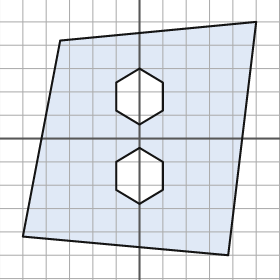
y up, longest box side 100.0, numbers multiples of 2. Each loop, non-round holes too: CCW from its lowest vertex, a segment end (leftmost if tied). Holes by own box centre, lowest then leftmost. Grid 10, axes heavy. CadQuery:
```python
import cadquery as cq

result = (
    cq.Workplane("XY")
    .moveTo(38.0, -50.0)
    .lineTo(50.0, 50.0)
    .lineTo(-34.0, 42.0)
    .lineTo(-50.0, -42.0)
    .close()
    .moveTo(0.0, -28.0)
    .lineTo(10.0, -22.0)
    .lineTo(10.0, -10.0)
    .lineTo(0.0, -4.0)
    .lineTo(-10.0, -10.0)
    .lineTo(-10.0, -22.0)
    .close()
    .moveTo(0.0, 6.0)
    .lineTo(10.0, 12.0)
    .lineTo(10.0, 24.0)
    .lineTo(0.0, 30.0)
    .lineTo(-10.0, 24.0)
    .lineTo(-10.0, 12.0)
    .close()
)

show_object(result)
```